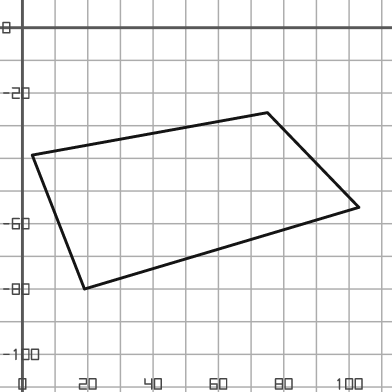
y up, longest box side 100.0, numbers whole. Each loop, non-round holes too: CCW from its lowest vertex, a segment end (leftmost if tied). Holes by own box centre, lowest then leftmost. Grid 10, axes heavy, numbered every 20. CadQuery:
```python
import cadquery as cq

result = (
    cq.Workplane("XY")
    .moveTo(19.0, -80.0)
    .lineTo(103.0, -55.0)
    .lineTo(75.0, -26.0)
    .lineTo(3.0, -39.0)
    .close()
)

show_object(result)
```